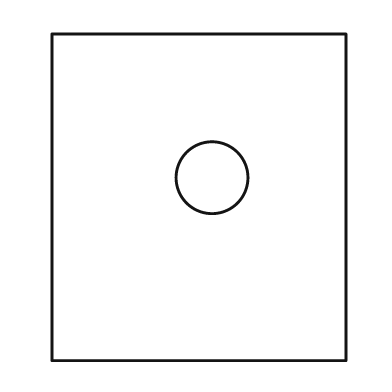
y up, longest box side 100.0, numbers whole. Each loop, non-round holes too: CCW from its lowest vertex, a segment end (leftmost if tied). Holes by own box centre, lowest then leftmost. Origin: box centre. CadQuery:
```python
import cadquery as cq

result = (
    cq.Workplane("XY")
    .moveTo(-45.0, -50.0)
    .lineTo(45.0, -50.0)
    .lineTo(45.0, 50.0)
    .lineTo(-45.0, 50.0)
    .close()
    .moveTo(4.0, 6.0)
    .circle(11.0)
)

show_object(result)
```